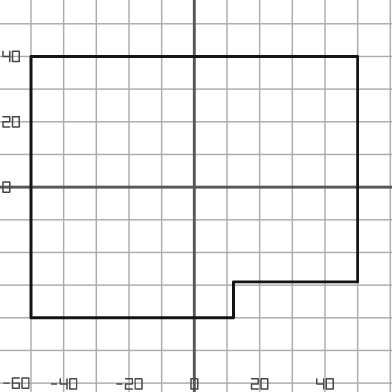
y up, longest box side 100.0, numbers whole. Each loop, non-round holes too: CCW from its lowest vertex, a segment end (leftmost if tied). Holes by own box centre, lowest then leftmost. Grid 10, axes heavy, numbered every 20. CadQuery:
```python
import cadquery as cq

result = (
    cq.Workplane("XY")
    .moveTo(-50.0, -40.0)
    .lineTo(12.0, -40.0)
    .lineTo(12.0, -29.0)
    .lineTo(50.0, -29.0)
    .lineTo(50.0, 40.0)
    .lineTo(-50.0, 40.0)
    .close()
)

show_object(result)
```